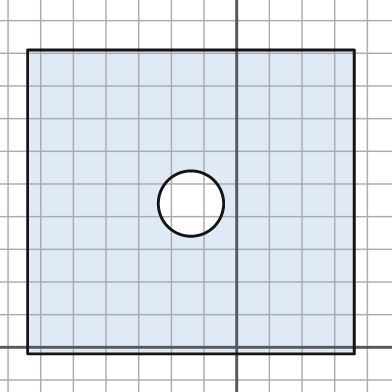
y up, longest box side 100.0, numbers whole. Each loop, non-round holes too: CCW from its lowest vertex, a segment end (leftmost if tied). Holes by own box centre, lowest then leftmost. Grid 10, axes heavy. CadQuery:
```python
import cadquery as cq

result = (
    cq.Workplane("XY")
    .moveTo(-64.0, -2.0)
    .lineTo(36.0, -2.0)
    .lineTo(36.0, 91.0)
    .lineTo(-64.0, 91.0)
    .close()
    .moveTo(-14.0, 44.0)
    .circle(10.0)
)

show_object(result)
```